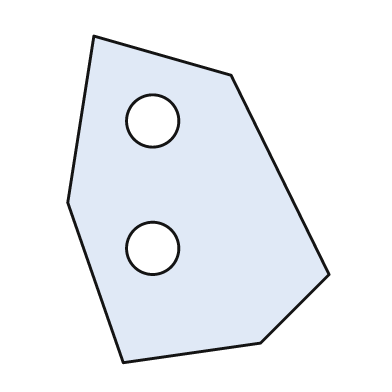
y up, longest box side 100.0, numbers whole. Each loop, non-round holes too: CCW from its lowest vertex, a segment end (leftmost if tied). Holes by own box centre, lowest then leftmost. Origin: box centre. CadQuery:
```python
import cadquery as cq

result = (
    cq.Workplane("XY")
    .moveTo(-23.0, -50.0)
    .lineTo(19.0, -44.0)
    .lineTo(40.0, -23.0)
    .lineTo(10.0, 38.0)
    .lineTo(-32.0, 50.0)
    .lineTo(-40.0, -1.0)
    .close()
    .moveTo(-14.0, -15.0)
    .circle(8.0)
    .moveTo(-14.0, 24.0)
    .circle(8.0)
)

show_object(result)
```